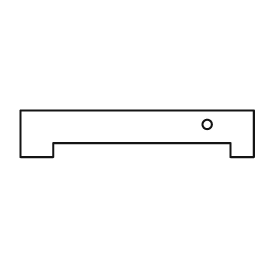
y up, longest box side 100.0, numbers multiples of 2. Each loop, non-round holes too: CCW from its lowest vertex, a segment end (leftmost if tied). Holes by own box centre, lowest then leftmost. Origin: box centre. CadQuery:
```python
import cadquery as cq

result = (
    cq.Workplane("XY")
    .moveTo(-50.0, -10.0)
    .lineTo(-36.0, -10.0)
    .lineTo(-36.0, -4.0)
    .lineTo(40.0, -4.0)
    .lineTo(40.0, -10.0)
    .lineTo(50.0, -10.0)
    .lineTo(50.0, 10.0)
    .lineTo(-50.0, 10.0)
    .close()
    .moveTo(30.0, 4.0)
    .circle(2.0)
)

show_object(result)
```